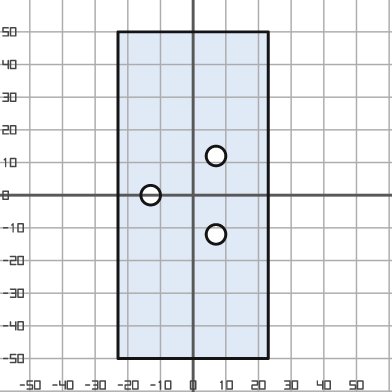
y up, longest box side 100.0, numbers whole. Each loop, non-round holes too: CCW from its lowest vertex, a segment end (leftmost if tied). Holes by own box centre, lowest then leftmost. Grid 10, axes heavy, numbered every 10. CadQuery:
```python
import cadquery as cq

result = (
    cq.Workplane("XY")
    .moveTo(-23.0, -50.0)
    .lineTo(23.0, -50.0)
    .lineTo(23.0, 50.0)
    .lineTo(-23.0, 50.0)
    .close()
    .moveTo(7.0, -12.0)
    .circle(3.0)
    .moveTo(-13.0, 0.0)
    .circle(3.0)
    .moveTo(7.0, 12.0)
    .circle(3.0)
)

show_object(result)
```